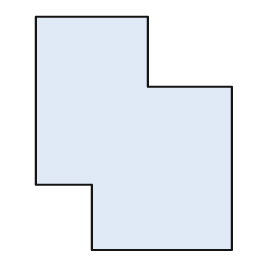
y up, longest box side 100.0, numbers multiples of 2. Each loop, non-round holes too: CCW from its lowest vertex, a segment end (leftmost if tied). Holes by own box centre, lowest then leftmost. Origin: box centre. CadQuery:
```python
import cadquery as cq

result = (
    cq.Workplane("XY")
    .moveTo(-18.0, -50.0)
    .lineTo(42.0, -50.0)
    .lineTo(42.0, 20.0)
    .lineTo(6.0, 20.0)
    .lineTo(6.0, 50.0)
    .lineTo(-42.0, 50.0)
    .lineTo(-42.0, -22.0)
    .lineTo(-18.0, -22.0)
    .close()
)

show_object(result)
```